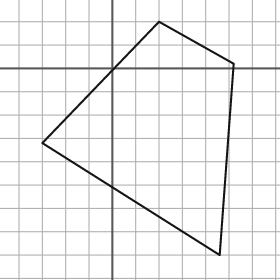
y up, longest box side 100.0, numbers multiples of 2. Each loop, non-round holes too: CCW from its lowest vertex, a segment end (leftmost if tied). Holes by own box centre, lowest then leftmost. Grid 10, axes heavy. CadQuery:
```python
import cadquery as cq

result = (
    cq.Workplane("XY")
    .moveTo(46.0, -80.0)
    .lineTo(52.0, 2.0)
    .lineTo(20.0, 20.0)
    .lineTo(-30.0, -32.0)
    .close()
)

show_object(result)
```